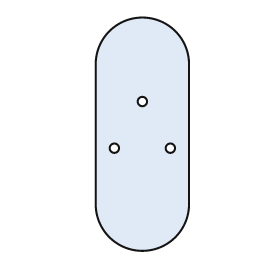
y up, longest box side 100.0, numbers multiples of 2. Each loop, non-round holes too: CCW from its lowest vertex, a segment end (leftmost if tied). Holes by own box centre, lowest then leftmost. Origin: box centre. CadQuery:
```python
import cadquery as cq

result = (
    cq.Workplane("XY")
    .moveTo(-20.0, -30.0)
    .threePointArc((0.0, -50.0), (20.0, -30.0))
    .lineTo(20.0, 30.0)
    .threePointArc((0.0, 50.0), (-20.0, 30.0))
    .close()
    .moveTo(-12.0, -6.0)
    .circle(2.0)
    .moveTo(12.0, -6.0)
    .circle(2.0)
    .moveTo(0.0, 14.0)
    .circle(2.0)
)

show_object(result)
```